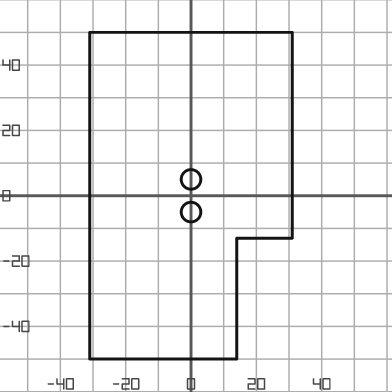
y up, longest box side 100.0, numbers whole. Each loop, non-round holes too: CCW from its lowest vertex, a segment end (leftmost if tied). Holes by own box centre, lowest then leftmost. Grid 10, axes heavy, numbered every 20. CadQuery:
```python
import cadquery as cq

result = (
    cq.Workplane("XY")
    .moveTo(-31.0, -50.0)
    .lineTo(14.0, -50.0)
    .lineTo(14.0, -13.0)
    .lineTo(31.0, -13.0)
    .lineTo(31.0, 50.0)
    .lineTo(-31.0, 50.0)
    .close()
    .moveTo(0.0, -5.0)
    .circle(3.0)
    .moveTo(0.0, 5.0)
    .circle(3.0)
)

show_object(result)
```